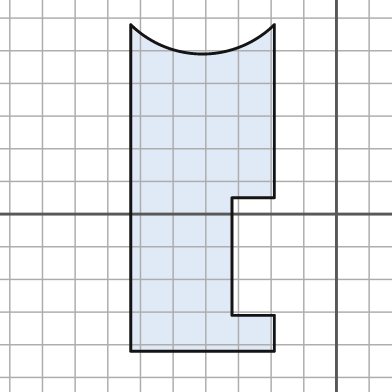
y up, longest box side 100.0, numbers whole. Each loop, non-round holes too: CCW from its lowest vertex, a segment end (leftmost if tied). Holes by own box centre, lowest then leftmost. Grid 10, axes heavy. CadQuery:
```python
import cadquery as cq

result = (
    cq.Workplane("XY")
    .moveTo(-63.0, -42.0)
    .lineTo(-19.0, -42.0)
    .lineTo(-19.0, -31.0)
    .lineTo(-32.0, -31.0)
    .lineTo(-32.0, 5.0)
    .lineTo(-19.0, 5.0)
    .lineTo(-19.0, 58.0)
    .threePointArc((-41.0, 49.0), (-63.0, 58.0))
    .close()
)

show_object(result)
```